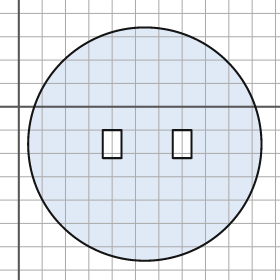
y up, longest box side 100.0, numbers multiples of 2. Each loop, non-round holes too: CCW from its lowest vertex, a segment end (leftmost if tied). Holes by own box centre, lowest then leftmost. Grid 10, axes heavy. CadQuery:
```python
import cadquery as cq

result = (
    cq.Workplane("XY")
    .moveTo(54.0, -16.0)
    .circle(50.0)
    .moveTo(36.0, -22.0)
    .lineTo(44.0, -22.0)
    .lineTo(44.0, -10.0)
    .lineTo(36.0, -10.0)
    .close()
    .moveTo(66.0, -22.0)
    .lineTo(74.0, -22.0)
    .lineTo(74.0, -10.0)
    .lineTo(66.0, -10.0)
    .close()
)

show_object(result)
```